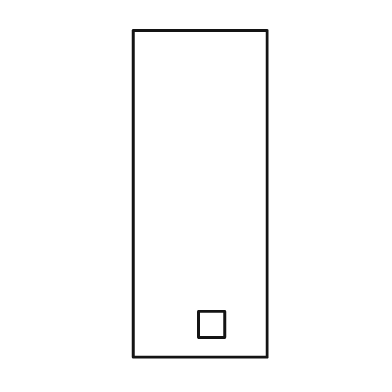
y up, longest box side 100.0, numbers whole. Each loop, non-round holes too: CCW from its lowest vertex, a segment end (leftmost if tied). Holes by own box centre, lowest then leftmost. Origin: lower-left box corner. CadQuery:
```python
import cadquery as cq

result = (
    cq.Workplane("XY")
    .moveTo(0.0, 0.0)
    .lineTo(41.0, 0.0)
    .lineTo(41.0, 100.0)
    .lineTo(0.0, 100.0)
    .close()
    .moveTo(20.0, 6.0)
    .lineTo(28.0, 6.0)
    .lineTo(28.0, 14.0)
    .lineTo(20.0, 14.0)
    .close()
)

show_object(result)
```